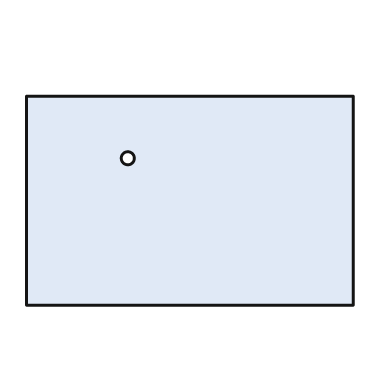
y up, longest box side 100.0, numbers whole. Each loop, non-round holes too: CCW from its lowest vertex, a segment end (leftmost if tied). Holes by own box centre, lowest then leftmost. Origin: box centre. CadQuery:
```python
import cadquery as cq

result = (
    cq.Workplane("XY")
    .moveTo(-50.0, -32.0)
    .lineTo(50.0, -32.0)
    .lineTo(50.0, 32.0)
    .lineTo(-50.0, 32.0)
    .close()
    .moveTo(-19.0, 13.0)
    .circle(2.0)
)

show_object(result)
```